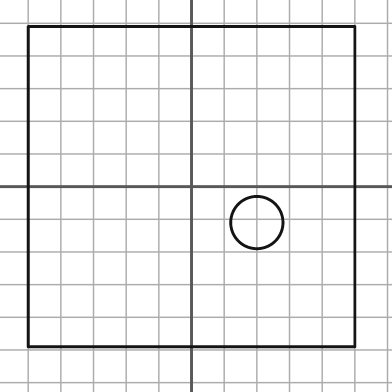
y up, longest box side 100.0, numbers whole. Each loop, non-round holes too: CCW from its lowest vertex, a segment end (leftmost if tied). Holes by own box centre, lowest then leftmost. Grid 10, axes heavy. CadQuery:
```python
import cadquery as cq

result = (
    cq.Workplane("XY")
    .moveTo(-50.0, -49.0)
    .lineTo(50.0, -49.0)
    .lineTo(50.0, 49.0)
    .lineTo(-50.0, 49.0)
    .close()
    .moveTo(20.0, -11.0)
    .circle(8.0)
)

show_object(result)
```